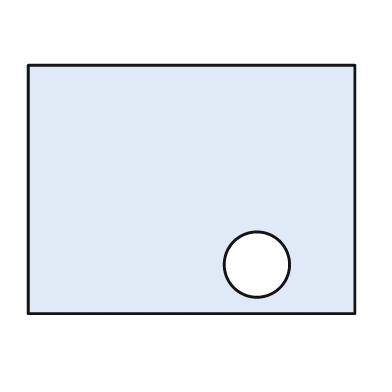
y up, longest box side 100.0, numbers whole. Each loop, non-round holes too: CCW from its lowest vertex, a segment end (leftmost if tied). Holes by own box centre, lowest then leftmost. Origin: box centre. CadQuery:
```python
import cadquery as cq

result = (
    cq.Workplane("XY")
    .moveTo(-50.0, -38.0)
    .lineTo(50.0, -38.0)
    .lineTo(50.0, 38.0)
    .lineTo(-50.0, 38.0)
    .close()
    .moveTo(20.0, -23.0)
    .circle(10.0)
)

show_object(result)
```